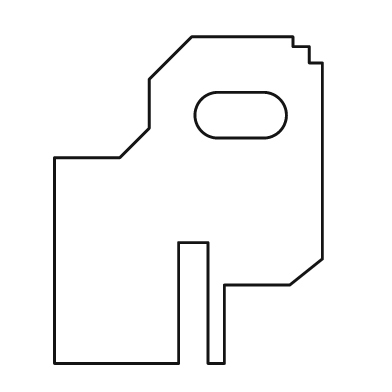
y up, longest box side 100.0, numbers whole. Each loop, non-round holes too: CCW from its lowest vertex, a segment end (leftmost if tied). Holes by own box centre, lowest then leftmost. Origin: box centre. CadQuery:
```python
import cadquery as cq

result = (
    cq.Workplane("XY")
    .moveTo(-41.0, -50.0)
    .lineTo(-3.0, -50.0)
    .lineTo(-3.0, -13.0)
    .lineTo(6.0, -13.0)
    .lineTo(6.0, -50.0)
    .lineTo(11.0, -50.0)
    .lineTo(11.0, -26.0)
    .lineTo(31.0, -26.0)
    .lineTo(41.0, -18.0)
    .lineTo(41.0, 42.0)
    .lineTo(37.0, 42.0)
    .lineTo(37.0, 47.0)
    .lineTo(32.0, 47.0)
    .lineTo(32.0, 50.0)
    .lineTo(1.0, 50.0)
    .lineTo(-12.0, 37.0)
    .lineTo(-12.0, 22.0)
    .lineTo(-21.0, 13.0)
    .lineTo(-41.0, 13.0)
    .close()
    .moveTo(9.0, 19.0)
    .lineTo(23.0, 19.0)
    .threePointArc((30.0, 26.0), (23.0, 33.0))
    .lineTo(9.0, 33.0)
    .threePointArc((2.0, 26.0), (9.0, 19.0))
    .close()
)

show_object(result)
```